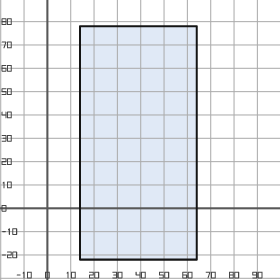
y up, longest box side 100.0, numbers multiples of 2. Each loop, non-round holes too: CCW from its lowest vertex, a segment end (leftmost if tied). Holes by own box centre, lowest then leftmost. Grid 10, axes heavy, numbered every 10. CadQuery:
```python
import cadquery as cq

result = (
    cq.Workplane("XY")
    .moveTo(14.0, -22.0)
    .lineTo(64.0, -22.0)
    .lineTo(64.0, 78.0)
    .lineTo(14.0, 78.0)
    .close()
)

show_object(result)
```